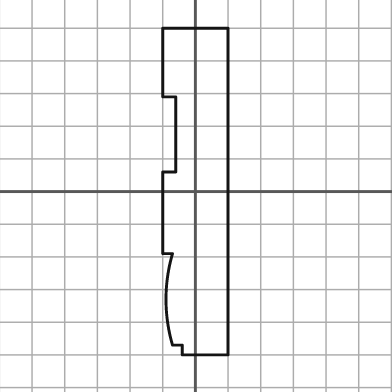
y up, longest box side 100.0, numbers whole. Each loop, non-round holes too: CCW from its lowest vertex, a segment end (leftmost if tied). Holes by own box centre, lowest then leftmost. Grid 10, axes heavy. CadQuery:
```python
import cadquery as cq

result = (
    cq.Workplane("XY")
    .moveTo(-4.0, -50.0)
    .lineTo(10.0, -50.0)
    .lineTo(10.0, 50.0)
    .lineTo(-10.0, 50.0)
    .lineTo(-10.0, 29.0)
    .lineTo(-6.0, 29.0)
    .lineTo(-6.0, 6.0)
    .lineTo(-10.0, 6.0)
    .lineTo(-10.0, -19.0)
    .lineTo(-7.0, -19.0)
    .threePointArc((-9.0, -33.0), (-7.0, -47.0))
    .lineTo(-4.0, -47.0)
    .close()
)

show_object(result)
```